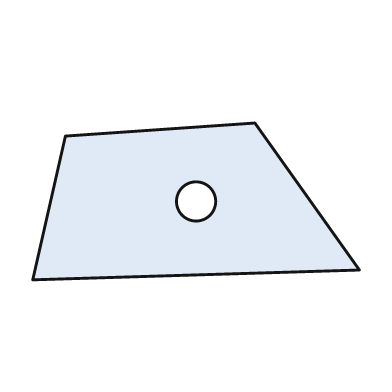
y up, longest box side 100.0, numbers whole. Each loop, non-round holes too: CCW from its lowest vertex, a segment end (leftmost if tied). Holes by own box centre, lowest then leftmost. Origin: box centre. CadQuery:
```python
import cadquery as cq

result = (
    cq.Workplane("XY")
    .moveTo(-50.0, -24.0)
    .lineTo(50.0, -21.0)
    .lineTo(18.0, 24.0)
    .lineTo(-40.0, 20.0)
    .close()
    .moveTo(0.0, 0.0)
    .circle(6.0)
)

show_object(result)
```